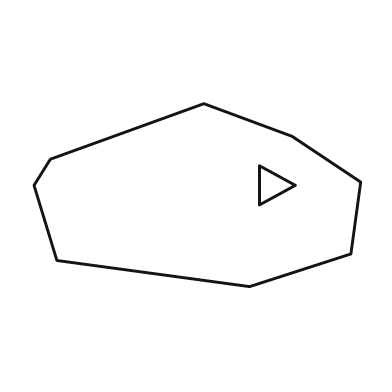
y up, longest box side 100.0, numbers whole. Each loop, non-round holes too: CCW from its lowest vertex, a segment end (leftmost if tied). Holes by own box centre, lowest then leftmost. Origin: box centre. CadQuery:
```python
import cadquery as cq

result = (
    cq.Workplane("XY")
    .moveTo(16.0, -28.0)
    .lineTo(47.0, -18.0)
    .lineTo(50.0, 4.0)
    .lineTo(29.0, 18.0)
    .lineTo(2.0, 28.0)
    .lineTo(-45.0, 11.0)
    .lineTo(-50.0, 3.0)
    .lineTo(-43.0, -20.0)
    .close()
    .moveTo(19.0, -3.0)
    .lineTo(30.0, 3.0)
    .lineTo(19.0, 9.0)
    .close()
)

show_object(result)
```